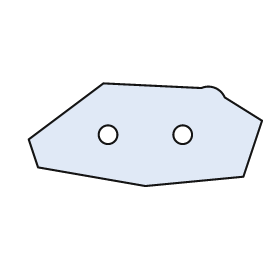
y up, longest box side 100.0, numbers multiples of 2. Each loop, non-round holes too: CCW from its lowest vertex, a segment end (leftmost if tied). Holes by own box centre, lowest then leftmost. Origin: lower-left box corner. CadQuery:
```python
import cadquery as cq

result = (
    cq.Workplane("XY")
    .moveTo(50.0, 0.0)
    .lineTo(92.0, 4.0)
    .lineTo(100.0, 28.0)
    .lineTo(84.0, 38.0)
    .threePointArc((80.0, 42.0), (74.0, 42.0))
    .lineTo(32.0, 44.0)
    .lineTo(0.0, 20.0)
    .lineTo(4.0, 8.0)
    .close()
    .moveTo(34.0, 22.0)
    .circle(4.0)
    .moveTo(66.0, 22.0)
    .circle(4.0)
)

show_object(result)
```